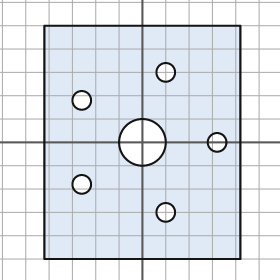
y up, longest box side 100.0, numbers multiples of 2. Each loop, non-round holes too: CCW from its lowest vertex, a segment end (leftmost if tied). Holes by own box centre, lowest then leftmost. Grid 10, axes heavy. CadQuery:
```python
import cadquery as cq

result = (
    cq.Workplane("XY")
    .moveTo(-42.0, -50.0)
    .lineTo(42.0, -50.0)
    .lineTo(42.0, 50.0)
    .lineTo(-42.0, 50.0)
    .close()
    .moveTo(10.0, -30.0)
    .circle(4.0)
    .moveTo(-26.0, -18.0)
    .circle(4.0)
    .moveTo(0.0, 0.0)
    .circle(10.0)
    .moveTo(32.0, 0.0)
    .circle(4.0)
    .moveTo(-26.0, 18.0)
    .circle(4.0)
    .moveTo(10.0, 30.0)
    .circle(4.0)
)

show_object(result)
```